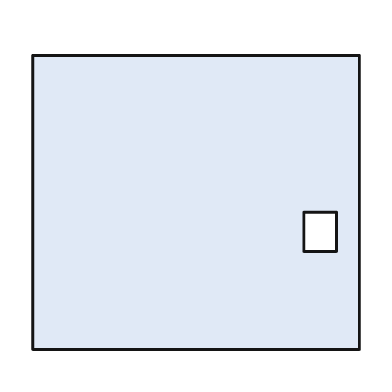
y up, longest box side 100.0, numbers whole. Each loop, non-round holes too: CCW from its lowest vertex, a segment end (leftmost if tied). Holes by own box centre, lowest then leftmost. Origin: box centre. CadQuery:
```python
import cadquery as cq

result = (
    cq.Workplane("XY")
    .moveTo(-50.0, -45.0)
    .lineTo(50.0, -45.0)
    .lineTo(50.0, 45.0)
    .lineTo(-50.0, 45.0)
    .close()
    .moveTo(33.0, -15.0)
    .lineTo(43.0, -15.0)
    .lineTo(43.0, -3.0)
    .lineTo(33.0, -3.0)
    .close()
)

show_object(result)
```